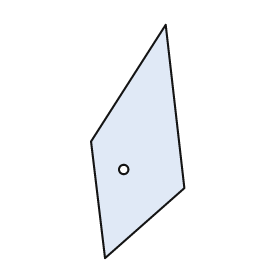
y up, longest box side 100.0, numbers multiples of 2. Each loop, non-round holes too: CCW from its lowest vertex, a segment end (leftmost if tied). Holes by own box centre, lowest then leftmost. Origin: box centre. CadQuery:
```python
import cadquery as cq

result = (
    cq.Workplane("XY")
    .moveTo(-14.0, -50.0)
    .lineTo(20.0, -20.0)
    .lineTo(12.0, 50.0)
    .lineTo(-20.0, 0.0)
    .close()
    .moveTo(-6.0, -12.0)
    .circle(2.0)
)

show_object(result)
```